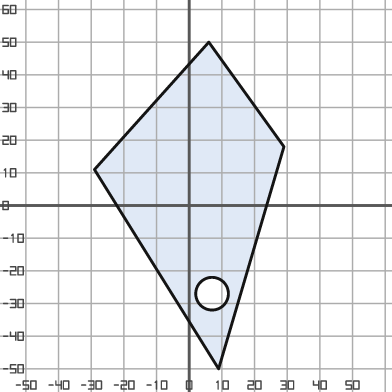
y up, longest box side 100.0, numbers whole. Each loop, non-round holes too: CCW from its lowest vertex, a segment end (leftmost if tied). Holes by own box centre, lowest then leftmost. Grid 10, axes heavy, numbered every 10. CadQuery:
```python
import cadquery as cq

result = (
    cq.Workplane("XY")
    .moveTo(9.0, -50.0)
    .lineTo(29.0, 18.0)
    .lineTo(6.0, 50.0)
    .lineTo(-29.0, 11.0)
    .close()
    .moveTo(7.0, -27.0)
    .circle(5.0)
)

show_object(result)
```